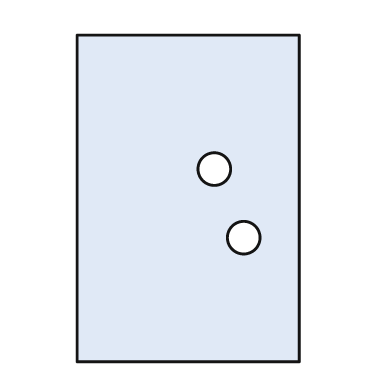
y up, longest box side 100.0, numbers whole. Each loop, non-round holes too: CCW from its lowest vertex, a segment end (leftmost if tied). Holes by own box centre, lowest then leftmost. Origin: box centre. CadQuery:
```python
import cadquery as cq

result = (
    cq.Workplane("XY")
    .moveTo(-34.0, -50.0)
    .lineTo(34.0, -50.0)
    .lineTo(34.0, 50.0)
    .lineTo(-34.0, 50.0)
    .close()
    .moveTo(17.0, -12.0)
    .circle(5.0)
    .moveTo(8.0, 9.0)
    .circle(5.0)
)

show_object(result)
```